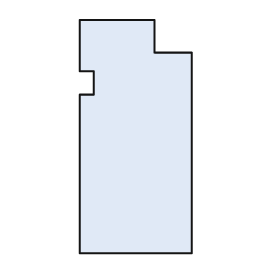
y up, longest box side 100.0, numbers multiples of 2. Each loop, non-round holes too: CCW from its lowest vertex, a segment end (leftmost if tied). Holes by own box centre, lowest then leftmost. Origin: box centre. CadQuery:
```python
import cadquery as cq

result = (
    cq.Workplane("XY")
    .moveTo(-24.0, -50.0)
    .lineTo(24.0, -50.0)
    .lineTo(24.0, 36.0)
    .lineTo(8.0, 36.0)
    .lineTo(8.0, 50.0)
    .lineTo(-24.0, 50.0)
    .lineTo(-24.0, 28.0)
    .lineTo(-18.0, 28.0)
    .lineTo(-18.0, 18.0)
    .lineTo(-24.0, 18.0)
    .close()
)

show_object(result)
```